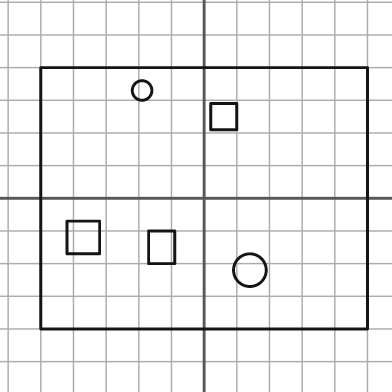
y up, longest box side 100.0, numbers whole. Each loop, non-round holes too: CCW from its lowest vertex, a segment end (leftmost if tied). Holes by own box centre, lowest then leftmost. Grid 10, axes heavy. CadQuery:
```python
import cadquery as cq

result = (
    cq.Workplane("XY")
    .moveTo(-50.0, -40.0)
    .lineTo(50.0, -40.0)
    .lineTo(50.0, 40.0)
    .lineTo(-50.0, 40.0)
    .close()
    .moveTo(14.0, -22.0)
    .circle(5.0)
    .moveTo(-17.0, -20.0)
    .lineTo(-9.0, -20.0)
    .lineTo(-9.0, -10.0)
    .lineTo(-17.0, -10.0)
    .close()
    .moveTo(-42.0, -17.0)
    .lineTo(-32.0, -17.0)
    .lineTo(-32.0, -7.0)
    .lineTo(-42.0, -7.0)
    .close()
    .moveTo(2.0, 21.0)
    .lineTo(10.0, 21.0)
    .lineTo(10.0, 29.0)
    .lineTo(2.0, 29.0)
    .close()
    .moveTo(-19.0, 33.0)
    .circle(3.0)
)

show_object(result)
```